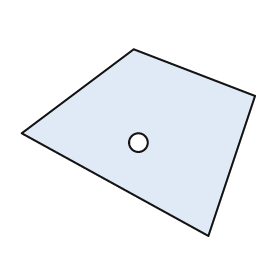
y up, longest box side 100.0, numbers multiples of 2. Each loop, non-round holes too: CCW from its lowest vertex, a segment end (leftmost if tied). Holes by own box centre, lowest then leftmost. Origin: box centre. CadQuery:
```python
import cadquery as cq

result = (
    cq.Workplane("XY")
    .moveTo(30.0, -40.0)
    .lineTo(50.0, 20.0)
    .lineTo(-2.0, 40.0)
    .lineTo(-50.0, 4.0)
    .close()
    .moveTo(0.0, 0.0)
    .circle(4.0)
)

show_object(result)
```